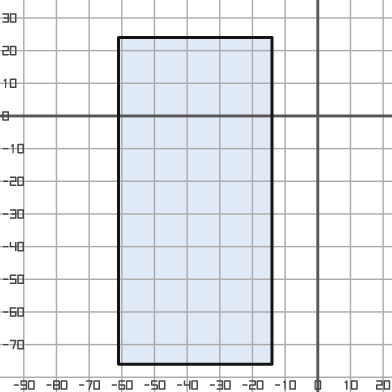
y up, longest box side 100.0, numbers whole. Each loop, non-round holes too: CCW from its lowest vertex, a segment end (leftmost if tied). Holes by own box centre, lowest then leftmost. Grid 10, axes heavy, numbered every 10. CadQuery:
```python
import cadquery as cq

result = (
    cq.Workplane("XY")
    .moveTo(-61.0, -76.0)
    .lineTo(-14.0, -76.0)
    .lineTo(-14.0, 24.0)
    .lineTo(-61.0, 24.0)
    .close()
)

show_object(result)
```